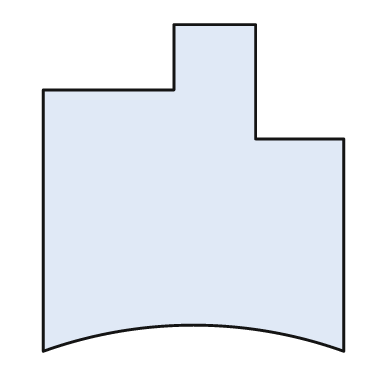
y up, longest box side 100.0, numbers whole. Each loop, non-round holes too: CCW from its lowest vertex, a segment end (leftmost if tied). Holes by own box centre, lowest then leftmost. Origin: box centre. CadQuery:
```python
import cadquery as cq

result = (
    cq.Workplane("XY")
    .moveTo(-46.0, -50.0)
    .threePointArc((0.0, -42.0), (46.0, -50.0))
    .lineTo(46.0, 15.0)
    .lineTo(19.0, 15.0)
    .lineTo(19.0, 50.0)
    .lineTo(-6.0, 50.0)
    .lineTo(-6.0, 30.0)
    .lineTo(-46.0, 30.0)
    .close()
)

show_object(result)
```